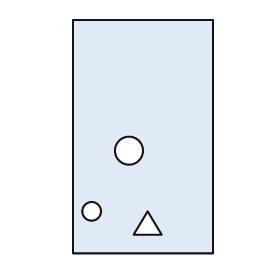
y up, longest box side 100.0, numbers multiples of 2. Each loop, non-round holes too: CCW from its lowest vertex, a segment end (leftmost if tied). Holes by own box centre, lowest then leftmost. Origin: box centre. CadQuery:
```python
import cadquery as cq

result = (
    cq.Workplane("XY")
    .moveTo(-30.0, -50.0)
    .lineTo(30.0, -50.0)
    .lineTo(30.0, 50.0)
    .lineTo(-30.0, 50.0)
    .close()
    .moveTo(-4.0, -42.0)
    .lineTo(8.0, -42.0)
    .lineTo(2.0, -32.0)
    .close()
    .moveTo(-22.0, -32.0)
    .circle(4.0)
    .moveTo(-6.0, -6.0)
    .circle(6.0)
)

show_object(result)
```